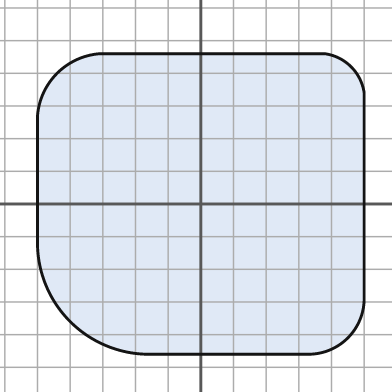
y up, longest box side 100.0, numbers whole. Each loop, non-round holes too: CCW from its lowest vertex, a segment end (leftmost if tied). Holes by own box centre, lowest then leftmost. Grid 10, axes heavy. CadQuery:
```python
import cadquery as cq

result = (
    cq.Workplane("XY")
    .moveTo(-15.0, -46.0)
    .lineTo(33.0, -46.0)
    .threePointArc((45.0, -41.0), (50.0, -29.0))
    .lineTo(50.0, 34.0)
    .threePointArc((46.0, 42.0), (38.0, 46.0))
    .lineTo(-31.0, 46.0)
    .threePointArc((-44.0, 40.0), (-50.0, 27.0))
    .lineTo(-50.0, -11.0)
    .threePointArc((-40.0, -36.0), (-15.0, -46.0))
    .close()
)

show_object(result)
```